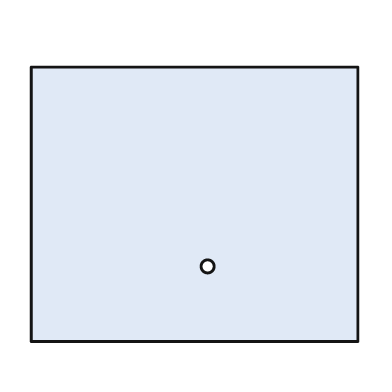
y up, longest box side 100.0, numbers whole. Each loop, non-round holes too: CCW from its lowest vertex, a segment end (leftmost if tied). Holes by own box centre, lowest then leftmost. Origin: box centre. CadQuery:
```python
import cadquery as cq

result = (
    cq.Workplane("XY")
    .moveTo(-50.0, -42.0)
    .lineTo(50.0, -42.0)
    .lineTo(50.0, 42.0)
    .lineTo(-50.0, 42.0)
    .close()
    .moveTo(4.0, -19.0)
    .circle(2.0)
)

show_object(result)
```